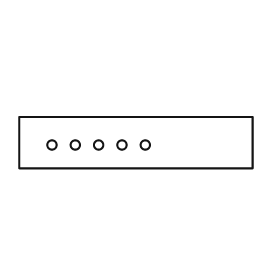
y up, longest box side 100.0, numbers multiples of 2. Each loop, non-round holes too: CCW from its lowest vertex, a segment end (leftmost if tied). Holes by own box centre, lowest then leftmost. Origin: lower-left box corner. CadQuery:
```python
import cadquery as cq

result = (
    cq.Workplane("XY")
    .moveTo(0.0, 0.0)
    .lineTo(100.0, 0.0)
    .lineTo(100.0, 22.0)
    .lineTo(0.0, 22.0)
    .close()
    .moveTo(14.0, 10.0)
    .circle(2.0)
    .moveTo(24.0, 10.0)
    .circle(2.0)
    .moveTo(34.0, 10.0)
    .circle(2.0)
    .moveTo(44.0, 10.0)
    .circle(2.0)
    .moveTo(54.0, 10.0)
    .circle(2.0)
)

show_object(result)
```